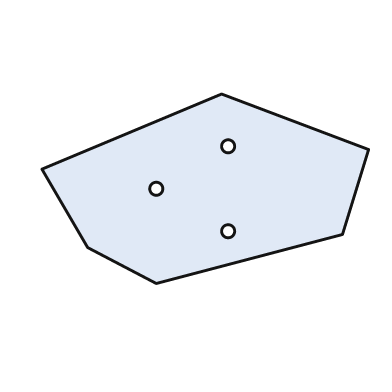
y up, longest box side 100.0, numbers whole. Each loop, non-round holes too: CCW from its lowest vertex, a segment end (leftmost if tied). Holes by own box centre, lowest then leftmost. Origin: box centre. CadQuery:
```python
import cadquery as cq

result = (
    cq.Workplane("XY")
    .moveTo(-15.0, -29.0)
    .lineTo(42.0, -14.0)
    .lineTo(50.0, 12.0)
    .lineTo(5.0, 29.0)
    .lineTo(-50.0, 6.0)
    .lineTo(-36.0, -18.0)
    .close()
    .moveTo(7.0, -13.0)
    .circle(2.0)
    .moveTo(-15.0, 0.0)
    .circle(2.0)
    .moveTo(7.0, 13.0)
    .circle(2.0)
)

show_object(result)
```